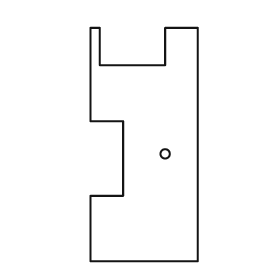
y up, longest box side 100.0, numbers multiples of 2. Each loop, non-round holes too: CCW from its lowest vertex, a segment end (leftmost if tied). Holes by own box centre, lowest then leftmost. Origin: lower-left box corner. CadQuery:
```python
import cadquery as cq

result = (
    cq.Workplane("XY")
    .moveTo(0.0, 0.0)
    .lineTo(46.0, 0.0)
    .lineTo(46.0, 100.0)
    .lineTo(32.0, 100.0)
    .lineTo(32.0, 84.0)
    .lineTo(4.0, 84.0)
    .lineTo(4.0, 100.0)
    .lineTo(0.0, 100.0)
    .lineTo(0.0, 60.0)
    .lineTo(14.0, 60.0)
    .lineTo(14.0, 28.0)
    .lineTo(0.0, 28.0)
    .close()
    .moveTo(32.0, 46.0)
    .circle(2.0)
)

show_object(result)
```